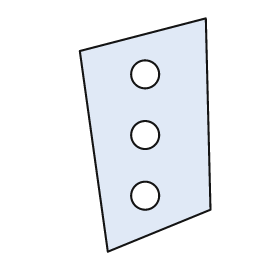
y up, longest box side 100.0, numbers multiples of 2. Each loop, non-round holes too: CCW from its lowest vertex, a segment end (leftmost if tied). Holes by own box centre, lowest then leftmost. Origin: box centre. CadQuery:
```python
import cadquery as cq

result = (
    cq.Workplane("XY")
    .moveTo(-16.0, -50.0)
    .lineTo(28.0, -32.0)
    .lineTo(26.0, 50.0)
    .lineTo(-28.0, 36.0)
    .close()
    .moveTo(0.0, -26.0)
    .circle(6.0)
    .moveTo(0.0, 0.0)
    .circle(6.0)
    .moveTo(0.0, 26.0)
    .circle(6.0)
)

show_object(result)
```